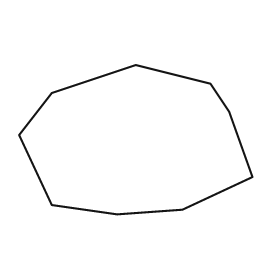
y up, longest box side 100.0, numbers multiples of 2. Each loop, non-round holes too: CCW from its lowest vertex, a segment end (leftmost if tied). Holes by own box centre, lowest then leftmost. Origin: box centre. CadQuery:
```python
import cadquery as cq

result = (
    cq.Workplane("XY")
    .moveTo(-8.0, -32.0)
    .lineTo(20.0, -30.0)
    .lineTo(50.0, -16.0)
    .lineTo(40.0, 12.0)
    .lineTo(32.0, 24.0)
    .lineTo(0.0, 32.0)
    .lineTo(-36.0, 20.0)
    .lineTo(-50.0, 2.0)
    .lineTo(-36.0, -28.0)
    .close()
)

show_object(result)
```